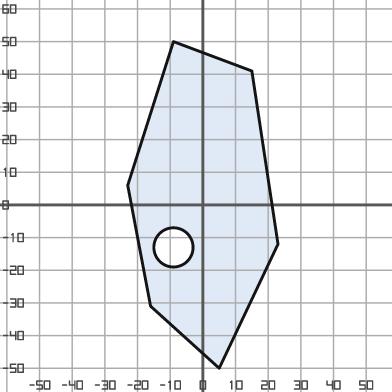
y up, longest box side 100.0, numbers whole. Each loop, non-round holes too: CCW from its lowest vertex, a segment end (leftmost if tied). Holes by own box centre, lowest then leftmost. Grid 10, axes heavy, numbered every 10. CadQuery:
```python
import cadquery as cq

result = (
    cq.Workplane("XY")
    .moveTo(5.0, -50.0)
    .lineTo(23.0, -12.0)
    .lineTo(15.0, 41.0)
    .lineTo(-9.0, 50.0)
    .lineTo(-23.0, 6.0)
    .lineTo(-16.0, -31.0)
    .close()
    .moveTo(-9.0, -13.0)
    .circle(6.0)
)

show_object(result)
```